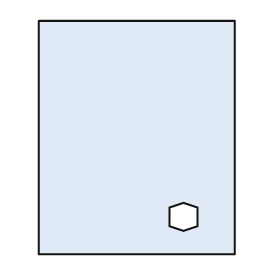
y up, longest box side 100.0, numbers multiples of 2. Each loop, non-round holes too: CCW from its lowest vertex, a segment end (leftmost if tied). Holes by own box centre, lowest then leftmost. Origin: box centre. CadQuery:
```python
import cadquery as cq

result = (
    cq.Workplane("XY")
    .moveTo(-42.0, -50.0)
    .lineTo(42.0, -50.0)
    .lineTo(42.0, 50.0)
    .lineTo(-42.0, 50.0)
    .close()
    .moveTo(20.0, -40.0)
    .lineTo(26.0, -38.0)
    .lineTo(26.0, -30.0)
    .lineTo(20.0, -28.0)
    .lineTo(14.0, -30.0)
    .lineTo(14.0, -38.0)
    .close()
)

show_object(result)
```